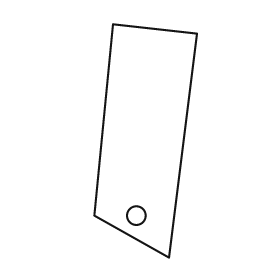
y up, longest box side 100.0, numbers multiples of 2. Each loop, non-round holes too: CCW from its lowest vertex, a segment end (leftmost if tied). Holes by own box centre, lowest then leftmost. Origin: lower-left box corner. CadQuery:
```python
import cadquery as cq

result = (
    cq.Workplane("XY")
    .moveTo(32.0, 0.0)
    .lineTo(44.0, 96.0)
    .lineTo(8.0, 100.0)
    .lineTo(0.0, 18.0)
    .close()
    .moveTo(18.0, 18.0)
    .circle(4.0)
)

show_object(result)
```